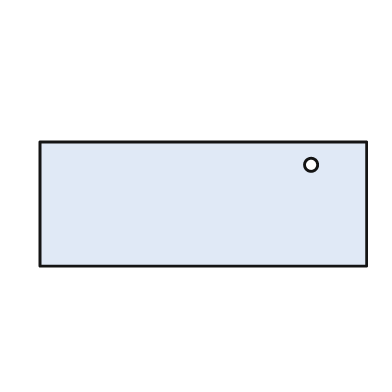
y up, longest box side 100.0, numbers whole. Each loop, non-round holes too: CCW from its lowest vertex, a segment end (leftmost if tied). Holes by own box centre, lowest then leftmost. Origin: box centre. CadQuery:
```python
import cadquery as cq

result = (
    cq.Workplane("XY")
    .moveTo(-50.0, -19.0)
    .lineTo(50.0, -19.0)
    .lineTo(50.0, 19.0)
    .lineTo(-50.0, 19.0)
    .close()
    .moveTo(33.0, 12.0)
    .circle(2.0)
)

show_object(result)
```